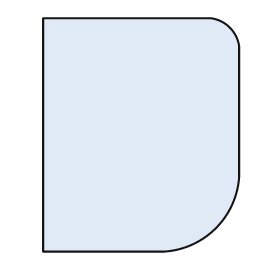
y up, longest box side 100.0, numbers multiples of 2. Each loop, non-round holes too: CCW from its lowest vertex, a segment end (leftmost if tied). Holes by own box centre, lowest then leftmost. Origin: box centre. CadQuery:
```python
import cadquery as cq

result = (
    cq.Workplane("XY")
    .moveTo(-42.0, -50.0)
    .lineTo(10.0, -50.0)
    .threePointArc((32.0, -40.0), (42.0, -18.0))
    .lineTo(42.0, 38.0)
    .threePointArc((38.0, 46.0), (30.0, 50.0))
    .lineTo(-42.0, 50.0)
    .close()
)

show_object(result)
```